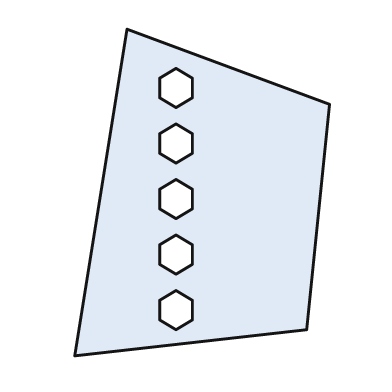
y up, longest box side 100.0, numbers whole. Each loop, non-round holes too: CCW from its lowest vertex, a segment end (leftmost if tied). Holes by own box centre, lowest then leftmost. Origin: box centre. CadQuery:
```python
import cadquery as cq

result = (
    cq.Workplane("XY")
    .moveTo(-39.0, -50.0)
    .lineTo(32.0, -42.0)
    .lineTo(39.0, 27.0)
    .lineTo(-23.0, 50.0)
    .close()
    .moveTo(-8.0, -42.0)
    .lineTo(-3.0, -39.0)
    .lineTo(-3.0, -33.0)
    .lineTo(-8.0, -30.0)
    .lineTo(-13.0, -33.0)
    .lineTo(-13.0, -39.0)
    .close()
    .moveTo(-8.0, -25.0)
    .lineTo(-3.0, -22.0)
    .lineTo(-3.0, -16.0)
    .lineTo(-8.0, -13.0)
    .lineTo(-13.0, -16.0)
    .lineTo(-13.0, -22.0)
    .close()
    .moveTo(-8.0, -8.0)
    .lineTo(-3.0, -5.0)
    .lineTo(-3.0, 1.0)
    .lineTo(-8.0, 4.0)
    .lineTo(-13.0, 1.0)
    .lineTo(-13.0, -5.0)
    .close()
    .moveTo(-8.0, 9.0)
    .lineTo(-3.0, 12.0)
    .lineTo(-3.0, 18.0)
    .lineTo(-8.0, 21.0)
    .lineTo(-13.0, 18.0)
    .lineTo(-13.0, 12.0)
    .close()
    .moveTo(-8.0, 26.0)
    .lineTo(-3.0, 29.0)
    .lineTo(-3.0, 35.0)
    .lineTo(-8.0, 38.0)
    .lineTo(-13.0, 35.0)
    .lineTo(-13.0, 29.0)
    .close()
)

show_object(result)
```